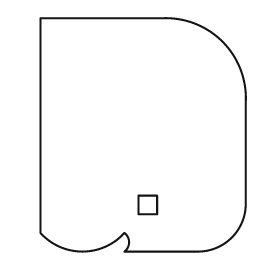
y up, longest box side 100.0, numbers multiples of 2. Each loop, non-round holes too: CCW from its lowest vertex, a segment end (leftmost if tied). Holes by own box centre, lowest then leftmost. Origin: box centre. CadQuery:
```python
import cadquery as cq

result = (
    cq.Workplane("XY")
    .moveTo(-8.0, -50.0)
    .lineTo(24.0, -50.0)
    .threePointArc((38.0, -44.0), (44.0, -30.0))
    .lineTo(44.0, 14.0)
    .threePointArc((34.0, 40.0), (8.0, 50.0))
    .lineTo(-44.0, 50.0)
    .lineTo(-44.0, -42.0)
    .threePointArc((-26.0, -50.0), (-8.0, -42.0))
    .threePointArc((-6.0, -46.0), (-8.0, -50.0))
    .close()
    .moveTo(-2.0, -34.0)
    .lineTo(6.0, -34.0)
    .lineTo(6.0, -26.0)
    .lineTo(-2.0, -26.0)
    .close()
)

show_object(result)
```